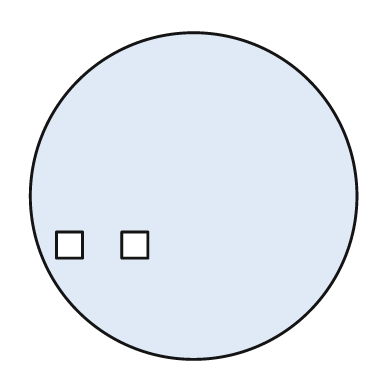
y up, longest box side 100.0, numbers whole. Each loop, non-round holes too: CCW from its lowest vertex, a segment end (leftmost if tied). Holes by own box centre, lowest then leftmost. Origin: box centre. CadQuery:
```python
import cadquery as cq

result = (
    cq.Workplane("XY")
    .moveTo(0.0, 0.0)
    .circle(50.0)
    .moveTo(-42.0, -19.0)
    .lineTo(-34.0, -19.0)
    .lineTo(-34.0, -11.0)
    .lineTo(-42.0, -11.0)
    .close()
    .moveTo(-22.0, -19.0)
    .lineTo(-14.0, -19.0)
    .lineTo(-14.0, -11.0)
    .lineTo(-22.0, -11.0)
    .close()
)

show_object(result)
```